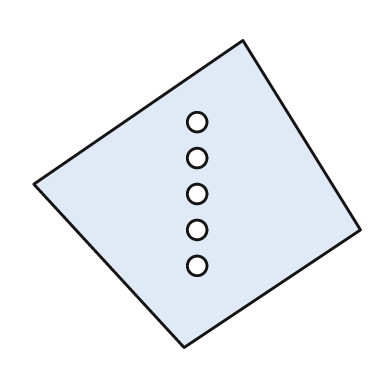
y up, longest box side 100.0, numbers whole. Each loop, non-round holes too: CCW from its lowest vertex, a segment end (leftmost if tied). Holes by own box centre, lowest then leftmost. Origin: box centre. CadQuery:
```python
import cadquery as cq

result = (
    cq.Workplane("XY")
    .moveTo(-4.0, -47.0)
    .lineTo(50.0, -11.0)
    .lineTo(14.0, 47.0)
    .lineTo(-50.0, 3.0)
    .close()
    .moveTo(0.0, -22.0)
    .circle(3.0)
    .moveTo(0.0, -11.0)
    .circle(3.0)
    .moveTo(0.0, 0.0)
    .circle(3.0)
    .moveTo(0.0, 11.0)
    .circle(3.0)
    .moveTo(0.0, 22.0)
    .circle(3.0)
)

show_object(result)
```